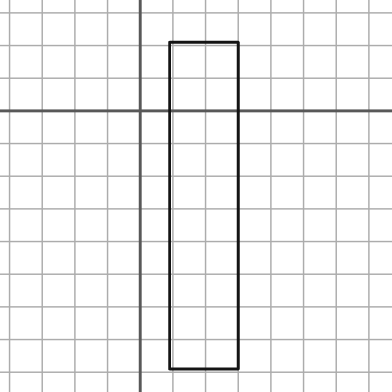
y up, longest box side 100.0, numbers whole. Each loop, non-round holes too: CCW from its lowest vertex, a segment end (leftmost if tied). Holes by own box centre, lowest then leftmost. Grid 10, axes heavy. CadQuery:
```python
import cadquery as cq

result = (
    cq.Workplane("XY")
    .moveTo(9.0, -79.0)
    .lineTo(30.0, -79.0)
    .lineTo(30.0, 21.0)
    .lineTo(9.0, 21.0)
    .close()
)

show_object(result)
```